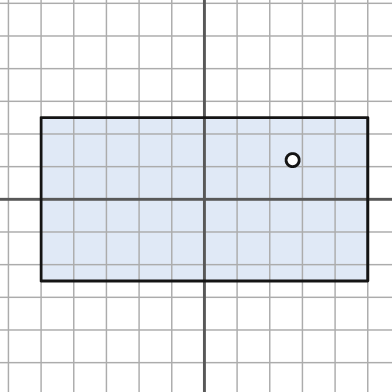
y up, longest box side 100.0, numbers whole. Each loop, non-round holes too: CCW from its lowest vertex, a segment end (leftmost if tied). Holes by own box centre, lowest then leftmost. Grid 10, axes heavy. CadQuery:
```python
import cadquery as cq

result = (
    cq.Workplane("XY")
    .moveTo(-50.0, -25.0)
    .lineTo(50.0, -25.0)
    .lineTo(50.0, 25.0)
    .lineTo(-50.0, 25.0)
    .close()
    .moveTo(27.0, 12.0)
    .circle(2.0)
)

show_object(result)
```